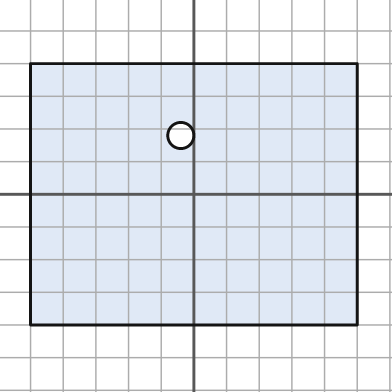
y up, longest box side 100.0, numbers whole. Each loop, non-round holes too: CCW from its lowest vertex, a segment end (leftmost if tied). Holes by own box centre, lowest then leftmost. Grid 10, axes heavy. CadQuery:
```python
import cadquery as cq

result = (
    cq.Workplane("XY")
    .moveTo(-50.0, -40.0)
    .lineTo(50.0, -40.0)
    .lineTo(50.0, 40.0)
    .lineTo(-50.0, 40.0)
    .close()
    .moveTo(-4.0, 18.0)
    .circle(4.0)
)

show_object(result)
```